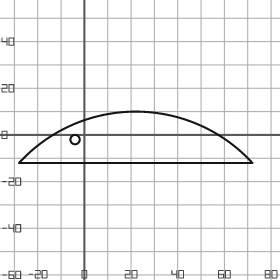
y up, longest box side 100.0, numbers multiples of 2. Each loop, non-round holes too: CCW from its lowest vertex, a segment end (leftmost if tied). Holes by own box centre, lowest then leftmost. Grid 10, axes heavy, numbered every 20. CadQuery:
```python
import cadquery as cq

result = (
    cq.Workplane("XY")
    .moveTo(-28.0, -12.0)
    .lineTo(72.0, -12.0)
    .threePointArc((22.0, 10.0), (-28.0, -12.0))
    .close()
    .moveTo(-4.0, -2.0)
    .circle(2.0)
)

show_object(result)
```